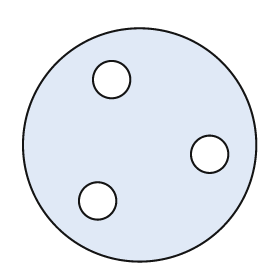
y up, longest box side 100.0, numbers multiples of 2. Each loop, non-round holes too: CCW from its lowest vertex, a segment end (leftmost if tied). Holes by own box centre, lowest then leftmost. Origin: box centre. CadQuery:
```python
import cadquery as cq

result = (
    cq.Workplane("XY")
    .moveTo(0.0, 0.0)
    .circle(50.0)
    .moveTo(-18.0, -24.0)
    .circle(8.0)
    .moveTo(30.0, -4.0)
    .circle(8.0)
    .moveTo(-12.0, 28.0)
    .circle(8.0)
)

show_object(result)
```